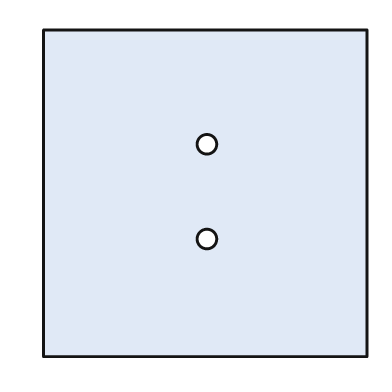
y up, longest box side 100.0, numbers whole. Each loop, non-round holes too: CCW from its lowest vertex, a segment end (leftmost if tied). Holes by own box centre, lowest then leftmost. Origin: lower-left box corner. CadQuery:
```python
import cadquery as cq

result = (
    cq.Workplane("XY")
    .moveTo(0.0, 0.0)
    .lineTo(99.0, 0.0)
    .lineTo(99.0, 100.0)
    .lineTo(0.0, 100.0)
    .close()
    .moveTo(50.0, 36.0)
    .circle(3.0)
    .moveTo(50.0, 65.0)
    .circle(3.0)
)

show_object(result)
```